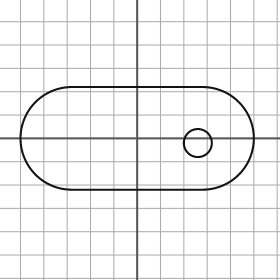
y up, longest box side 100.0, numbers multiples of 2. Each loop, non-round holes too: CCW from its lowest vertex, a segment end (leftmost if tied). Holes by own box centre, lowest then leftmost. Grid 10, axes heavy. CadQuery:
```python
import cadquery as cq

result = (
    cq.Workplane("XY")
    .moveTo(-28.0, -22.0)
    .lineTo(28.0, -22.0)
    .threePointArc((50.0, 0.0), (28.0, 22.0))
    .lineTo(-28.0, 22.0)
    .threePointArc((-50.0, 0.0), (-28.0, -22.0))
    .close()
    .moveTo(26.0, -2.0)
    .circle(6.0)
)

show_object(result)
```